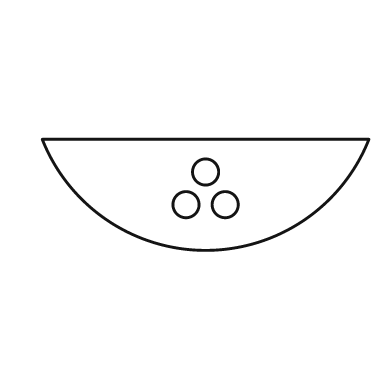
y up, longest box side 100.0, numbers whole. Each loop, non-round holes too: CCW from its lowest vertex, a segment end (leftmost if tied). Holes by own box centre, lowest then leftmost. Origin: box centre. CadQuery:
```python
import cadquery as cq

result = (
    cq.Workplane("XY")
    .moveTo(-50.0, 17.0)
    .threePointArc((0.0, -17.0), (50.0, 17.0))
    .close()
    .moveTo(-6.0, -3.0)
    .circle(4.0)
    .moveTo(6.0, -3.0)
    .circle(4.0)
    .moveTo(0.0, 7.0)
    .circle(4.0)
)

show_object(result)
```